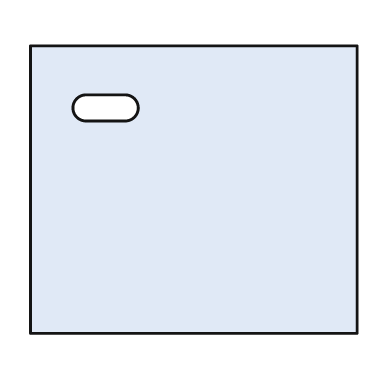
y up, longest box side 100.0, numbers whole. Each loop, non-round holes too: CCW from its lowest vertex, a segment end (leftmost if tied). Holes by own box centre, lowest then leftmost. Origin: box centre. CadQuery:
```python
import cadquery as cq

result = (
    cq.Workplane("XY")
    .moveTo(-50.0, -44.0)
    .lineTo(50.0, -44.0)
    .lineTo(50.0, 44.0)
    .lineTo(-50.0, 44.0)
    .close()
    .moveTo(-33.0, 21.0)
    .lineTo(-21.0, 21.0)
    .threePointArc((-17.0, 25.0), (-21.0, 29.0))
    .lineTo(-33.0, 29.0)
    .threePointArc((-37.0, 25.0), (-33.0, 21.0))
    .close()
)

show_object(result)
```